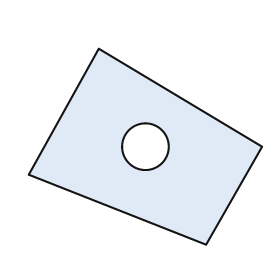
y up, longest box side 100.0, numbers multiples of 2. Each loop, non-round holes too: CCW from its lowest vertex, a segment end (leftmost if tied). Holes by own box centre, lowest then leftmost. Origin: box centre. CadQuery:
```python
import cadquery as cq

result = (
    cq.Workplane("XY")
    .moveTo(26.0, -42.0)
    .lineTo(50.0, 0.0)
    .lineTo(-20.0, 42.0)
    .lineTo(-50.0, -12.0)
    .close()
    .moveTo(0.0, 0.0)
    .circle(10.0)
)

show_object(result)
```